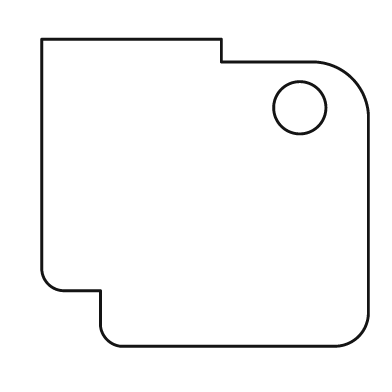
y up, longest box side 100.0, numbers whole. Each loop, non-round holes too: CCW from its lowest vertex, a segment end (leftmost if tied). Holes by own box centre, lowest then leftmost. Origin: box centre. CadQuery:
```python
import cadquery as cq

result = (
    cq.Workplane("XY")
    .moveTo(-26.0, -47.0)
    .lineTo(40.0, -47.0)
    .threePointArc((47.0, -44.0), (50.0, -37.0))
    .lineTo(50.0, 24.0)
    .threePointArc((45.0, 35.0), (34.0, 40.0))
    .lineTo(5.0, 40.0)
    .lineTo(5.0, 47.0)
    .lineTo(-50.0, 47.0)
    .lineTo(-50.0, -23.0)
    .threePointArc((-48.0, -28.0), (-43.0, -30.0))
    .lineTo(-32.0, -30.0)
    .lineTo(-32.0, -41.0)
    .threePointArc((-30.0, -45.0), (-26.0, -47.0))
    .close()
    .moveTo(29.0, 26.0)
    .circle(8.0)
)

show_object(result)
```